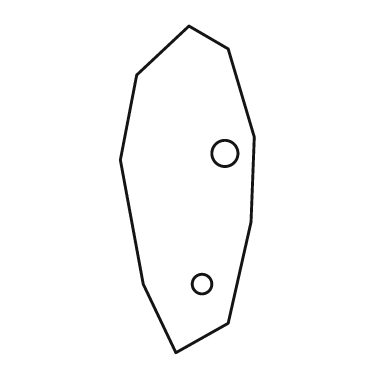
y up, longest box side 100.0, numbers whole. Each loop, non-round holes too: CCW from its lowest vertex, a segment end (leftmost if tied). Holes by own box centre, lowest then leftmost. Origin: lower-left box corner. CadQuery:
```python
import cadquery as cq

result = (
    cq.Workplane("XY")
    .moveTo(17.0, 0.0)
    .lineTo(33.0, 9.0)
    .lineTo(40.0, 40.0)
    .lineTo(41.0, 66.0)
    .lineTo(33.0, 93.0)
    .lineTo(21.0, 100.0)
    .lineTo(5.0, 85.0)
    .lineTo(0.0, 59.0)
    .lineTo(7.0, 21.0)
    .close()
    .moveTo(25.0, 21.0)
    .circle(3.0)
    .moveTo(32.0, 61.0)
    .circle(4.0)
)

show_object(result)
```